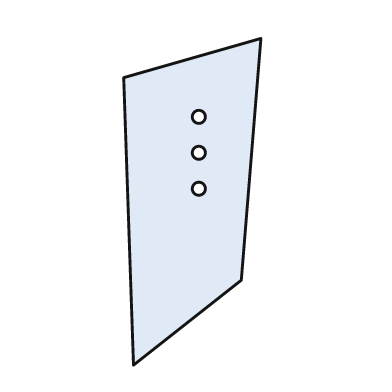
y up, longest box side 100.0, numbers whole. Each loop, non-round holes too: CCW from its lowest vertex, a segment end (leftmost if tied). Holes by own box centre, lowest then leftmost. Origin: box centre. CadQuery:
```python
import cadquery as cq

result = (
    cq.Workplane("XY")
    .moveTo(-18.0, -50.0)
    .lineTo(15.0, -24.0)
    .lineTo(21.0, 50.0)
    .lineTo(-21.0, 38.0)
    .close()
    .moveTo(2.0, 4.0)
    .circle(2.0)
    .moveTo(2.0, 15.0)
    .circle(2.0)
    .moveTo(2.0, 26.0)
    .circle(2.0)
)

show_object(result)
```